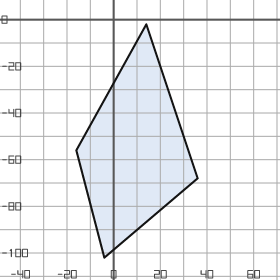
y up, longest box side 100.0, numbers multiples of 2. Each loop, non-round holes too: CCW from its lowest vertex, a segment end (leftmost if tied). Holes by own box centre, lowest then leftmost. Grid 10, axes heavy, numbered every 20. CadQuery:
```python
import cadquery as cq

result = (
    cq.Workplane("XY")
    .moveTo(-4.0, -102.0)
    .lineTo(36.0, -68.0)
    .lineTo(14.0, -2.0)
    .lineTo(-16.0, -56.0)
    .close()
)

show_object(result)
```